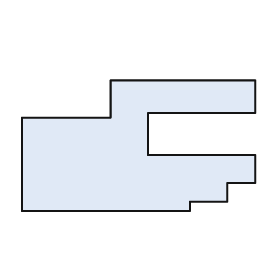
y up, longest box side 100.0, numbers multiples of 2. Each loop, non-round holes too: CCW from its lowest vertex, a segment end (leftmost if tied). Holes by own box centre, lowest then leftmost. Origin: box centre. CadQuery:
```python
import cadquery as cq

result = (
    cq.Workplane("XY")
    .moveTo(-50.0, -28.0)
    .lineTo(22.0, -28.0)
    .lineTo(22.0, -24.0)
    .lineTo(38.0, -24.0)
    .lineTo(38.0, -16.0)
    .lineTo(50.0, -16.0)
    .lineTo(50.0, -4.0)
    .lineTo(4.0, -4.0)
    .lineTo(4.0, 14.0)
    .lineTo(50.0, 14.0)
    .lineTo(50.0, 28.0)
    .lineTo(-12.0, 28.0)
    .lineTo(-12.0, 12.0)
    .lineTo(-50.0, 12.0)
    .close()
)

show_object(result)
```